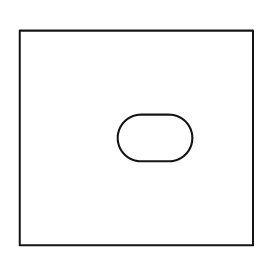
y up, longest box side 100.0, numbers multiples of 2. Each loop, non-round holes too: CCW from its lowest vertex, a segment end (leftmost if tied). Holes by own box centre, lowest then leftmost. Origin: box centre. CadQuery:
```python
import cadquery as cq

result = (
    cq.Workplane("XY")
    .moveTo(-50.0, -46.0)
    .lineTo(50.0, -46.0)
    .lineTo(50.0, 46.0)
    .lineTo(-50.0, 46.0)
    .close()
    .moveTo(2.0, -10.0)
    .lineTo(14.0, -10.0)
    .threePointArc((24.0, 0.0), (14.0, 10.0))
    .lineTo(2.0, 10.0)
    .threePointArc((-8.0, 0.0), (2.0, -10.0))
    .close()
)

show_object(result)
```